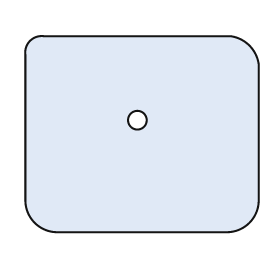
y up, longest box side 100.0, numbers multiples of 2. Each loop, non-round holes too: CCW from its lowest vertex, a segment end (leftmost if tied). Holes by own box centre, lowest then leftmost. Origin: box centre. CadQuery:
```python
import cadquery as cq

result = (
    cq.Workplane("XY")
    .moveTo(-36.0, -42.0)
    .lineTo(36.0, -42.0)
    .threePointArc((46.0, -38.0), (50.0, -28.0))
    .lineTo(50.0, 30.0)
    .threePointArc((46.0, 38.0), (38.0, 42.0))
    .lineTo(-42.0, 42.0)
    .threePointArc((-48.0, 40.0), (-50.0, 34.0))
    .lineTo(-50.0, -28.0)
    .threePointArc((-46.0, -38.0), (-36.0, -42.0))
    .close()
    .moveTo(-2.0, 6.0)
    .circle(4.0)
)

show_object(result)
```